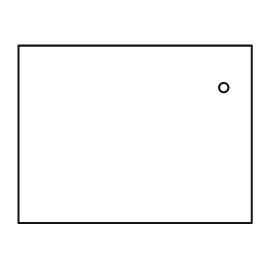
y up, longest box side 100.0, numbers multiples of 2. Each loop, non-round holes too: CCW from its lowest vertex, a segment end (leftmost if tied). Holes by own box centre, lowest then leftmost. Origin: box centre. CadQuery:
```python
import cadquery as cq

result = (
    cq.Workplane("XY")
    .moveTo(-50.0, -38.0)
    .lineTo(50.0, -38.0)
    .lineTo(50.0, 38.0)
    .lineTo(-50.0, 38.0)
    .close()
    .moveTo(38.0, 20.0)
    .circle(2.0)
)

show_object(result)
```